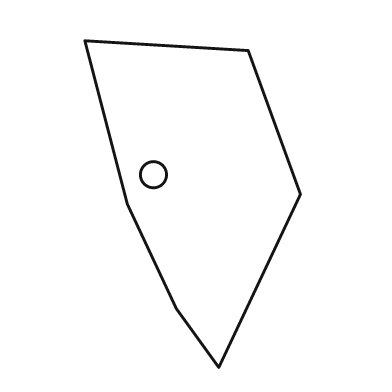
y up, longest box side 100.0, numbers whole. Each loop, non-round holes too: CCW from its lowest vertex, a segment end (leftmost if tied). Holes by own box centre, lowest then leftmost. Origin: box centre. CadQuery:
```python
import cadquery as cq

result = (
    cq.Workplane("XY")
    .moveTo(8.0, -50.0)
    .lineTo(33.0, 3.0)
    .lineTo(17.0, 47.0)
    .lineTo(-33.0, 50.0)
    .lineTo(-20.0, 0.0)
    .lineTo(-5.0, -32.0)
    .close()
    .moveTo(-12.0, 9.0)
    .circle(4.0)
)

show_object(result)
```